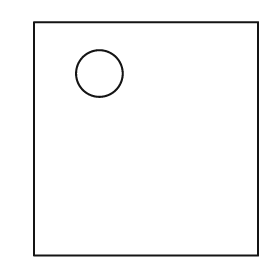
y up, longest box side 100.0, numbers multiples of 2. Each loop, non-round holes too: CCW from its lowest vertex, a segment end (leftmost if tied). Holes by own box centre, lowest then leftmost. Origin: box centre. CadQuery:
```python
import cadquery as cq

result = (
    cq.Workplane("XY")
    .moveTo(-48.0, -50.0)
    .lineTo(48.0, -50.0)
    .lineTo(48.0, 50.0)
    .lineTo(-48.0, 50.0)
    .close()
    .moveTo(-20.0, 28.0)
    .circle(10.0)
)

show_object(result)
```